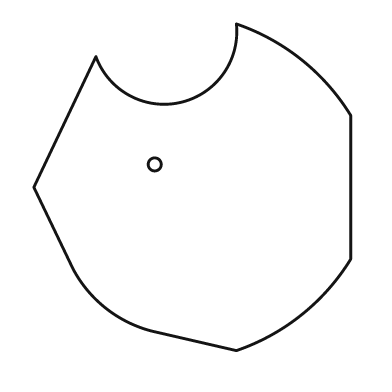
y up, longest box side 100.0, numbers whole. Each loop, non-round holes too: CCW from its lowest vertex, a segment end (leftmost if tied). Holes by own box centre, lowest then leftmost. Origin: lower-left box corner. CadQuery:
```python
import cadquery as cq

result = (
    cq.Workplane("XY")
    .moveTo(62.0, 0.0)
    .threePointArc((82.0, 11.0), (97.0, 28.0))
    .lineTo(97.0, 72.0)
    .threePointArc((82.0, 89.0), (62.0, 100.0))
    .threePointArc((45.0, 76.0), (19.0, 90.0))
    .lineTo(0.0, 50.0)
    .lineTo(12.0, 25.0)
    .threePointArc((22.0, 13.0), (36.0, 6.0))
    .close()
    .moveTo(37.0, 57.0)
    .circle(2.0)
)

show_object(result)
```